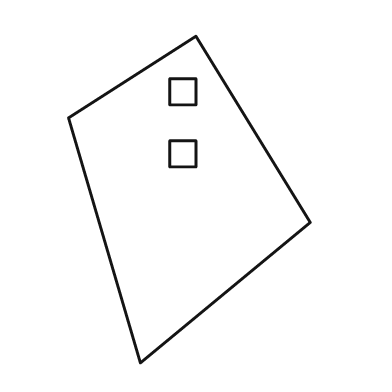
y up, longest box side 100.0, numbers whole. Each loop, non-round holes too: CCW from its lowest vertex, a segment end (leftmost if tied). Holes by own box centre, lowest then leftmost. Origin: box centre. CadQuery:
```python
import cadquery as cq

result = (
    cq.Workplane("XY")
    .moveTo(-15.0, -50.0)
    .lineTo(37.0, -7.0)
    .lineTo(2.0, 50.0)
    .lineTo(-37.0, 25.0)
    .close()
    .moveTo(-6.0, 10.0)
    .lineTo(2.0, 10.0)
    .lineTo(2.0, 18.0)
    .lineTo(-6.0, 18.0)
    .close()
    .moveTo(-6.0, 29.0)
    .lineTo(2.0, 29.0)
    .lineTo(2.0, 37.0)
    .lineTo(-6.0, 37.0)
    .close()
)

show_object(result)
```